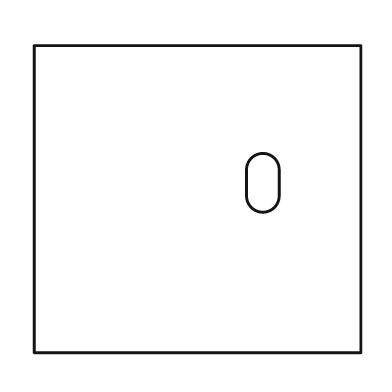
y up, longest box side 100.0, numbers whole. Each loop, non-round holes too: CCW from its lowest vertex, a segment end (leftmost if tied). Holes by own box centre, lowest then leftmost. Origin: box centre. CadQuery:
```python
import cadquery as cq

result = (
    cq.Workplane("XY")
    .moveTo(-50.0, -47.0)
    .lineTo(50.0, -47.0)
    .lineTo(50.0, 47.0)
    .lineTo(-50.0, 47.0)
    .close()
    .moveTo(15.0, 1.0)
    .threePointArc((20.0, -4.0), (25.0, 1.0))
    .lineTo(25.0, 9.0)
    .threePointArc((20.0, 14.0), (15.0, 9.0))
    .close()
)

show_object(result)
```